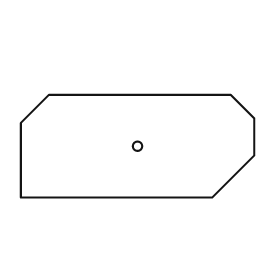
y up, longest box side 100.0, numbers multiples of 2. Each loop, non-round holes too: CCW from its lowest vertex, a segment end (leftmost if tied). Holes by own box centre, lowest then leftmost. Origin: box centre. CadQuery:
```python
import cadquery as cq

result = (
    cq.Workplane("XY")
    .moveTo(-50.0, -22.0)
    .lineTo(32.0, -22.0)
    .lineTo(50.0, -4.0)
    .lineTo(50.0, 12.0)
    .lineTo(40.0, 22.0)
    .lineTo(-38.0, 22.0)
    .lineTo(-50.0, 10.0)
    .close()
    .moveTo(0.0, 0.0)
    .circle(2.0)
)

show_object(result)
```